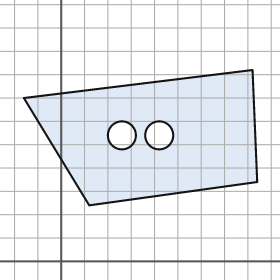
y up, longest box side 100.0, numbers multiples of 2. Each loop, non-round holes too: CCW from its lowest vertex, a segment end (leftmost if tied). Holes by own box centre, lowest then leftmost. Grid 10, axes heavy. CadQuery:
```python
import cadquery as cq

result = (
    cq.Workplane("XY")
    .moveTo(12.0, 24.0)
    .lineTo(84.0, 34.0)
    .lineTo(82.0, 82.0)
    .lineTo(-16.0, 70.0)
    .close()
    .moveTo(26.0, 54.0)
    .circle(6.0)
    .moveTo(42.0, 54.0)
    .circle(6.0)
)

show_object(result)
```